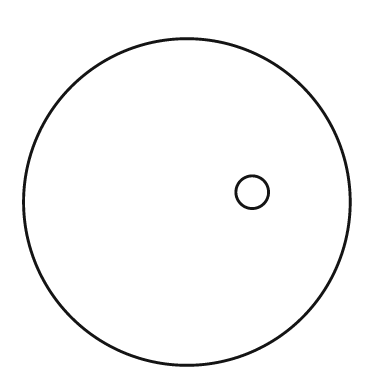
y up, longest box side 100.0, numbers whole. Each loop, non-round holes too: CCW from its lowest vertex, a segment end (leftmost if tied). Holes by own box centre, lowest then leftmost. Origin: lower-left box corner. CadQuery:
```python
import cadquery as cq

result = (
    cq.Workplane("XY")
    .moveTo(50.0, 50.0)
    .circle(50.0)
    .moveTo(70.0, 53.0)
    .circle(5.0)
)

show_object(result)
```